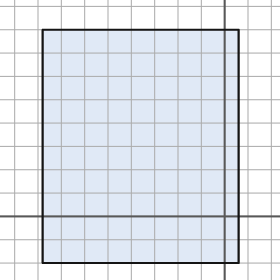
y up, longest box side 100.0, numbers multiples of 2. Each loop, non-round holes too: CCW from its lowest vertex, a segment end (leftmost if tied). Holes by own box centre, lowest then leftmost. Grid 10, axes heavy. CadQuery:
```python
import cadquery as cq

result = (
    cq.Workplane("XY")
    .moveTo(-78.0, -20.0)
    .lineTo(6.0, -20.0)
    .lineTo(6.0, 80.0)
    .lineTo(-78.0, 80.0)
    .close()
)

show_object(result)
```